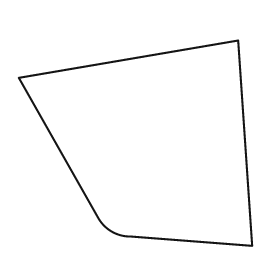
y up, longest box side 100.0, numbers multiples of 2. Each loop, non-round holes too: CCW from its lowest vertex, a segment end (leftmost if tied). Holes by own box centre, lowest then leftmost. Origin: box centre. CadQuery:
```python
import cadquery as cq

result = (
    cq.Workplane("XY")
    .moveTo(50.0, -44.0)
    .lineTo(44.0, 44.0)
    .lineTo(-50.0, 28.0)
    .lineTo(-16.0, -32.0)
    .threePointArc((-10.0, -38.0), (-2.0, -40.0))
    .close()
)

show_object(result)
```